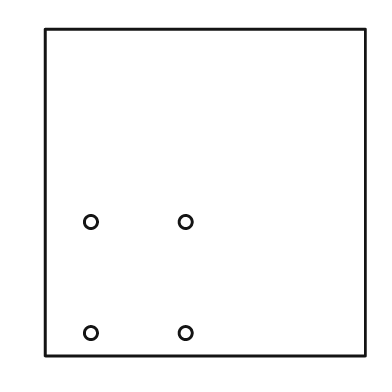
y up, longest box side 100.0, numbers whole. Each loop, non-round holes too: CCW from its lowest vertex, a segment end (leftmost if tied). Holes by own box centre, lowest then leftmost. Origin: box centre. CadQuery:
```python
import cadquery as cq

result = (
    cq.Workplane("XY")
    .moveTo(-49.0, -50.0)
    .lineTo(49.0, -50.0)
    .lineTo(49.0, 50.0)
    .lineTo(-49.0, 50.0)
    .close()
    .moveTo(-35.0, -43.0)
    .circle(2.0)
    .moveTo(-6.0, -43.0)
    .circle(2.0)
    .moveTo(-35.0, -9.0)
    .circle(2.0)
    .moveTo(-6.0, -9.0)
    .circle(2.0)
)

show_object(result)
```